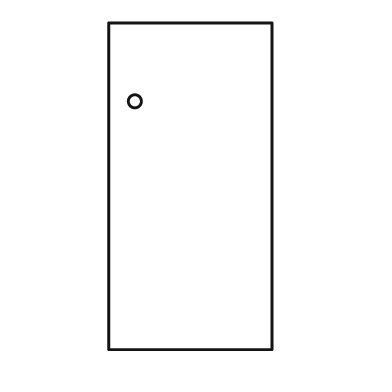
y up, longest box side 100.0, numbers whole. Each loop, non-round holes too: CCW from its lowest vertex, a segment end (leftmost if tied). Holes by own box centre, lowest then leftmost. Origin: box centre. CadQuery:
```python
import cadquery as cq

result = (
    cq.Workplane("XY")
    .moveTo(-25.0, -50.0)
    .lineTo(25.0, -50.0)
    .lineTo(25.0, 50.0)
    .lineTo(-25.0, 50.0)
    .close()
    .moveTo(-17.0, 26.0)
    .circle(2.0)
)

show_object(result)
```